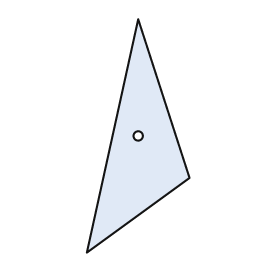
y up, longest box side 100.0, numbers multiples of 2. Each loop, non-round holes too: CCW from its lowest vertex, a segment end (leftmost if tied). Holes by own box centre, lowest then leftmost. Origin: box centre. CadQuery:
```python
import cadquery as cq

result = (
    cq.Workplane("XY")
    .moveTo(-22.0, -50.0)
    .lineTo(22.0, -18.0)
    .lineTo(0.0, 50.0)
    .close()
    .moveTo(0.0, 0.0)
    .circle(2.0)
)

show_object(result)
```